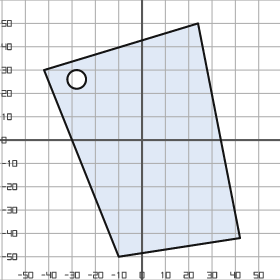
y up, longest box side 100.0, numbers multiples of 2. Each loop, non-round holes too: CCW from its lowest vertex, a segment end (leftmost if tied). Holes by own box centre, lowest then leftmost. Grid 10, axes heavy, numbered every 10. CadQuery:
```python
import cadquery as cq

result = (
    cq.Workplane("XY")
    .moveTo(-10.0, -50.0)
    .lineTo(42.0, -42.0)
    .lineTo(24.0, 50.0)
    .lineTo(-42.0, 30.0)
    .close()
    .moveTo(-28.0, 26.0)
    .circle(4.0)
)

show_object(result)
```